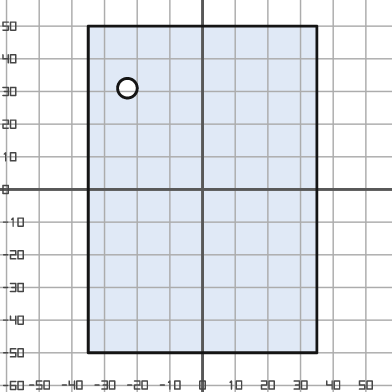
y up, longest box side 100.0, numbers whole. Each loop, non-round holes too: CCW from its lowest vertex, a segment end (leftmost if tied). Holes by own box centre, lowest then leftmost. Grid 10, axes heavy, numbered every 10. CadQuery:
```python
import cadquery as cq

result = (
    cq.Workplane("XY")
    .moveTo(-35.0, -50.0)
    .lineTo(35.0, -50.0)
    .lineTo(35.0, 50.0)
    .lineTo(-35.0, 50.0)
    .close()
    .moveTo(-23.0, 31.0)
    .circle(3.0)
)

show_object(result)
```